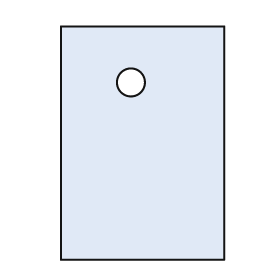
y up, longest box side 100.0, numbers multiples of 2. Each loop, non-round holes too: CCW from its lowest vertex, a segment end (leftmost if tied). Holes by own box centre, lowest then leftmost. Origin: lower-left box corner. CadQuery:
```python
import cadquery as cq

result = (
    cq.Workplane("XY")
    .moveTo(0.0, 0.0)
    .lineTo(70.0, 0.0)
    .lineTo(70.0, 100.0)
    .lineTo(0.0, 100.0)
    .close()
    .moveTo(30.0, 76.0)
    .circle(6.0)
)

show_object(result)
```